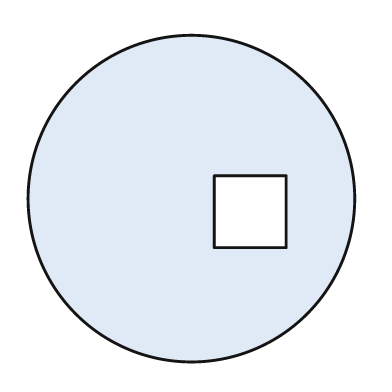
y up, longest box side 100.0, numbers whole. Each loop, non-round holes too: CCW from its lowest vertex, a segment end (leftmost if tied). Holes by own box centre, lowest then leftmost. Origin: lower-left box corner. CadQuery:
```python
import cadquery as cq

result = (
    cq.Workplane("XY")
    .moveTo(50.0, 50.0)
    .circle(50.0)
    .moveTo(57.0, 35.0)
    .lineTo(79.0, 35.0)
    .lineTo(79.0, 57.0)
    .lineTo(57.0, 57.0)
    .close()
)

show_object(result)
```